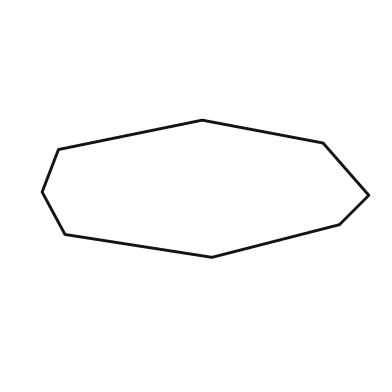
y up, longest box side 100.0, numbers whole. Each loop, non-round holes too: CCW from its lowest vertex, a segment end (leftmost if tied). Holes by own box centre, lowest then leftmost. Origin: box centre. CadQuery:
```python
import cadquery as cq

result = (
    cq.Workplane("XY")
    .moveTo(2.0, -21.0)
    .lineTo(41.0, -11.0)
    .lineTo(50.0, -2.0)
    .lineTo(36.0, 14.0)
    .lineTo(-1.0, 21.0)
    .lineTo(-45.0, 12.0)
    .lineTo(-50.0, -1.0)
    .lineTo(-43.0, -14.0)
    .close()
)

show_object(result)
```